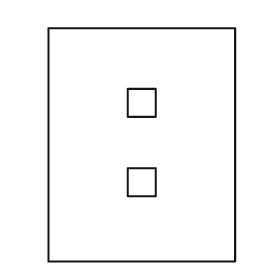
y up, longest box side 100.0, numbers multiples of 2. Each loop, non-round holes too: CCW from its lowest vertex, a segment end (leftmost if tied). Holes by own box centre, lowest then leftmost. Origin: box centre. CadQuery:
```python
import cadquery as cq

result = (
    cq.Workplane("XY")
    .moveTo(-40.0, -50.0)
    .lineTo(40.0, -50.0)
    .lineTo(40.0, 50.0)
    .lineTo(-40.0, 50.0)
    .close()
    .moveTo(-6.0, -22.0)
    .lineTo(6.0, -22.0)
    .lineTo(6.0, -10.0)
    .lineTo(-6.0, -10.0)
    .close()
    .moveTo(-6.0, 12.0)
    .lineTo(6.0, 12.0)
    .lineTo(6.0, 24.0)
    .lineTo(-6.0, 24.0)
    .close()
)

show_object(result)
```